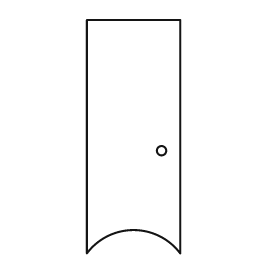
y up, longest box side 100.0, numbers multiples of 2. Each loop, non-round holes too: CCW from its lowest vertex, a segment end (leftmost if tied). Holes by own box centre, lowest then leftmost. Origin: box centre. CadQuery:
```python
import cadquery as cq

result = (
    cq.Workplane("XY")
    .moveTo(-20.0, -50.0)
    .threePointArc((0.0, -40.0), (20.0, -50.0))
    .lineTo(20.0, 50.0)
    .lineTo(-20.0, 50.0)
    .close()
    .moveTo(12.0, -6.0)
    .circle(2.0)
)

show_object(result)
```